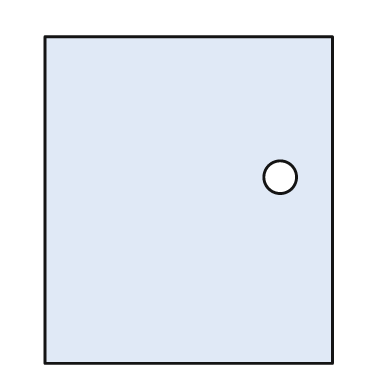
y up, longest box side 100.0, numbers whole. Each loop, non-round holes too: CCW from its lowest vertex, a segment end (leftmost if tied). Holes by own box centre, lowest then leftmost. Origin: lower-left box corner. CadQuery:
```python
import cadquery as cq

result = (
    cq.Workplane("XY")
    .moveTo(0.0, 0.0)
    .lineTo(88.0, 0.0)
    .lineTo(88.0, 100.0)
    .lineTo(0.0, 100.0)
    .close()
    .moveTo(72.0, 57.0)
    .circle(5.0)
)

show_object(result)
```